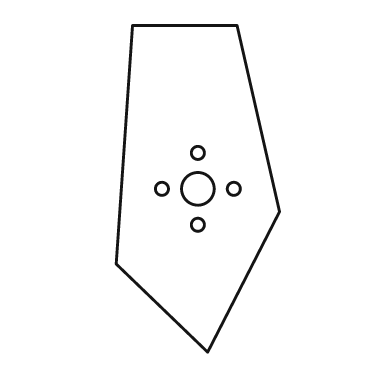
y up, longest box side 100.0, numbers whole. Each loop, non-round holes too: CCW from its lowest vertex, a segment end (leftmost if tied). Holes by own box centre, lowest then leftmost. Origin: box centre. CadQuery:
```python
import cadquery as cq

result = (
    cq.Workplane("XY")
    .moveTo(3.0, -50.0)
    .lineTo(25.0, -7.0)
    .lineTo(12.0, 50.0)
    .lineTo(-20.0, 50.0)
    .lineTo(-25.0, -23.0)
    .close()
    .moveTo(0.0, -11.0)
    .circle(2.0)
    .moveTo(-11.0, 0.0)
    .circle(2.0)
    .moveTo(0.0, 0.0)
    .circle(5.0)
    .moveTo(11.0, 0.0)
    .circle(2.0)
    .moveTo(0.0, 11.0)
    .circle(2.0)
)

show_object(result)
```